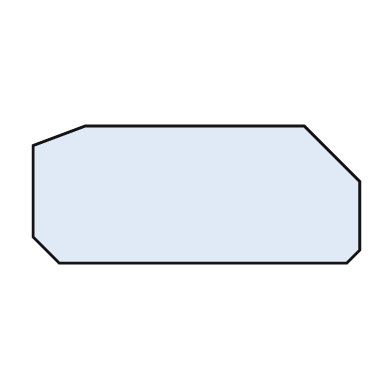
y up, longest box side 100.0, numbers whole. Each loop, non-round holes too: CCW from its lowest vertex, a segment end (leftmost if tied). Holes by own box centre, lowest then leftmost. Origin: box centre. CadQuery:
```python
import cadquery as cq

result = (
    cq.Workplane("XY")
    .moveTo(-42.0, -21.0)
    .lineTo(46.0, -21.0)
    .lineTo(50.0, -17.0)
    .lineTo(50.0, 4.0)
    .lineTo(33.0, 21.0)
    .lineTo(-34.0, 21.0)
    .lineTo(-50.0, 15.0)
    .lineTo(-50.0, -13.0)
    .close()
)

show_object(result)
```